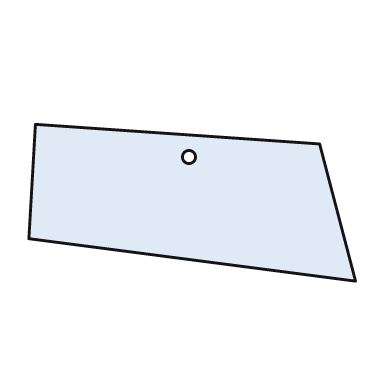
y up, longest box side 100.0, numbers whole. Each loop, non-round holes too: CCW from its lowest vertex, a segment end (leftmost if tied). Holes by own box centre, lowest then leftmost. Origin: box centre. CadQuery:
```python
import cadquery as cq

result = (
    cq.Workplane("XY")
    .moveTo(50.0, -24.0)
    .lineTo(39.0, 18.0)
    .lineTo(-48.0, 24.0)
    .lineTo(-50.0, -11.0)
    .close()
    .moveTo(-1.0, 14.0)
    .circle(2.0)
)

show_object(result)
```